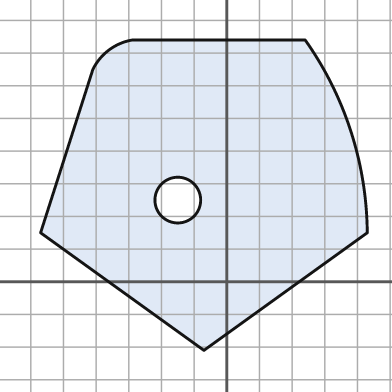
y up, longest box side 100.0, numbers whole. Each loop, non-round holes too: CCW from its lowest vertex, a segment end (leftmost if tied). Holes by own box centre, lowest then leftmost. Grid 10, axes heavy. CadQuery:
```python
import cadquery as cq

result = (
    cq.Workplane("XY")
    .moveTo(-7.0, -21.0)
    .lineTo(43.0, 15.0)
    .threePointArc((38.0, 46.0), (24.0, 74.0))
    .lineTo(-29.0, 74.0)
    .threePointArc((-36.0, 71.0), (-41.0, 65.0))
    .lineTo(-57.0, 15.0)
    .close()
    .moveTo(-15.0, 25.0)
    .circle(7.0)
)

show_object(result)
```